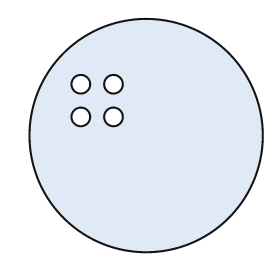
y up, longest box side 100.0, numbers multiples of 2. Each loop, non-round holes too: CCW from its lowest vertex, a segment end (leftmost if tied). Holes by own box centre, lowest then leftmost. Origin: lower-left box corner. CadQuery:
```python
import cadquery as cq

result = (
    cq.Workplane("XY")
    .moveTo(50.0, 50.0)
    .circle(50.0)
    .moveTo(22.0, 58.0)
    .circle(4.0)
    .moveTo(36.0, 58.0)
    .circle(4.0)
    .moveTo(22.0, 72.0)
    .circle(4.0)
    .moveTo(36.0, 72.0)
    .circle(4.0)
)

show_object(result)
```